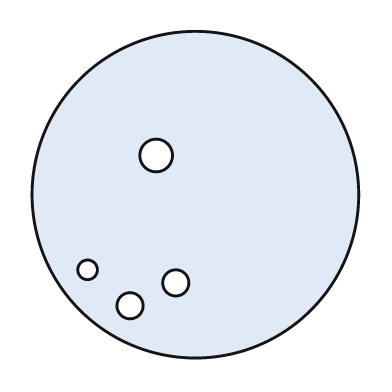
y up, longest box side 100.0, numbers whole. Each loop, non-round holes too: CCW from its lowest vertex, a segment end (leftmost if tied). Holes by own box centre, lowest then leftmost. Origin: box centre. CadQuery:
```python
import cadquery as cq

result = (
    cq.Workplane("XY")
    .moveTo(0.0, 0.0)
    .circle(50.0)
    .moveTo(-20.0, -34.0)
    .circle(4.0)
    .moveTo(-6.0, -27.0)
    .circle(4.0)
    .moveTo(-33.0, -23.0)
    .circle(3.0)
    .moveTo(-12.0, 12.0)
    .circle(5.0)
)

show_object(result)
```